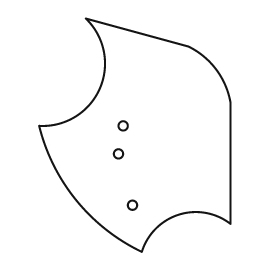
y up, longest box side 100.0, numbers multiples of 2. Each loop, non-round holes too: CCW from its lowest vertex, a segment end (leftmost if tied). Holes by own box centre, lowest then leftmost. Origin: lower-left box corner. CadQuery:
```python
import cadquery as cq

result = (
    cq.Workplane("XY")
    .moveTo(44.0, 0.0)
    .threePointArc((60.0, 16.0), (82.0, 12.0))
    .lineTo(82.0, 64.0)
    .threePointArc((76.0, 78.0), (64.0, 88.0))
    .lineTo(20.0, 100.0)
    .threePointArc((26.0, 70.0), (0.0, 54.0))
    .threePointArc((16.0, 22.0), (44.0, 0.0))
    .close()
    .moveTo(40.0, 20.0)
    .circle(2.0)
    .moveTo(34.0, 42.0)
    .circle(2.0)
    .moveTo(36.0, 54.0)
    .circle(2.0)
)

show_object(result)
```